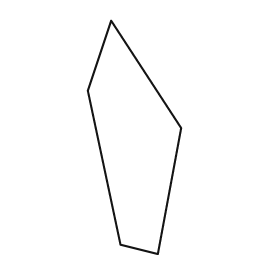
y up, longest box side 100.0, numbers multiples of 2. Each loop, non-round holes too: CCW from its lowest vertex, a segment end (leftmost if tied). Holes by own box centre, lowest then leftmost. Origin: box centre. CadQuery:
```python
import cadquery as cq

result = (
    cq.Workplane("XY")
    .moveTo(10.0, -50.0)
    .lineTo(20.0, 4.0)
    .lineTo(-10.0, 50.0)
    .lineTo(-20.0, 20.0)
    .lineTo(-6.0, -46.0)
    .close()
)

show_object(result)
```